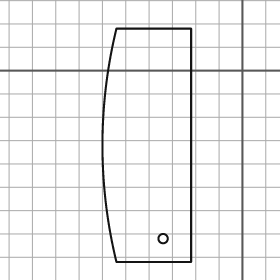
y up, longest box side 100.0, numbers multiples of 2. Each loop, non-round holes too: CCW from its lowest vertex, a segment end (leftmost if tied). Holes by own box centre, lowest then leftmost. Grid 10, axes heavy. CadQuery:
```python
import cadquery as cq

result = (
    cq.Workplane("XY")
    .moveTo(-54.0, -82.0)
    .lineTo(-22.0, -82.0)
    .lineTo(-22.0, 18.0)
    .lineTo(-54.0, 18.0)
    .threePointArc((-60.0, -32.0), (-54.0, -82.0))
    .close()
    .moveTo(-34.0, -72.0)
    .circle(2.0)
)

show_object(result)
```